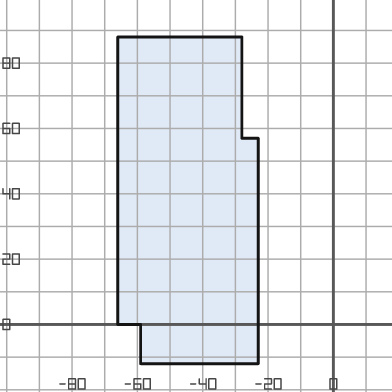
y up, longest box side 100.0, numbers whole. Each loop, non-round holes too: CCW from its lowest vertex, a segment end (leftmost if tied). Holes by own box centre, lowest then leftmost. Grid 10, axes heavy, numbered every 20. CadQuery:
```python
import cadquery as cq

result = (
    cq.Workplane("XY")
    .moveTo(-59.0, -12.0)
    .lineTo(-23.0, -12.0)
    .lineTo(-23.0, 57.0)
    .lineTo(-28.0, 57.0)
    .lineTo(-28.0, 88.0)
    .lineTo(-66.0, 88.0)
    .lineTo(-66.0, 0.0)
    .lineTo(-59.0, 0.0)
    .close()
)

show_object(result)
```